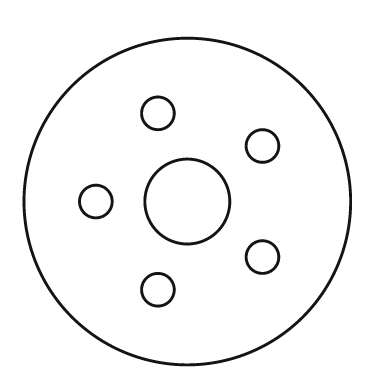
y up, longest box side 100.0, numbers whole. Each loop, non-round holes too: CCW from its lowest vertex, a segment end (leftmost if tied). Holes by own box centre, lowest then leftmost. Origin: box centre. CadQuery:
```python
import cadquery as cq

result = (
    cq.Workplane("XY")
    .moveTo(0.0, 0.0)
    .circle(50.0)
    .moveTo(-9.0, -27.0)
    .circle(5.0)
    .moveTo(23.0, -17.0)
    .circle(5.0)
    .moveTo(-28.0, 0.0)
    .circle(5.0)
    .moveTo(0.0, 0.0)
    .circle(13.0)
    .moveTo(23.0, 17.0)
    .circle(5.0)
    .moveTo(-9.0, 27.0)
    .circle(5.0)
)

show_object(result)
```